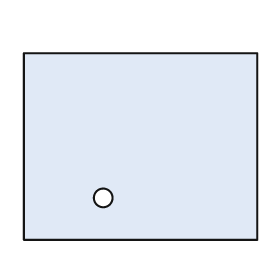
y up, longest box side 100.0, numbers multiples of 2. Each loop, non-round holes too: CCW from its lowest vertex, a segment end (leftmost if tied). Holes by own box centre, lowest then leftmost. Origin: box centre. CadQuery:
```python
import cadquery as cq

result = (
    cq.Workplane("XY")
    .moveTo(-50.0, -40.0)
    .lineTo(50.0, -40.0)
    .lineTo(50.0, 40.0)
    .lineTo(-50.0, 40.0)
    .close()
    .moveTo(-16.0, -22.0)
    .circle(4.0)
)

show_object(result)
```